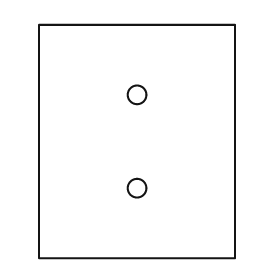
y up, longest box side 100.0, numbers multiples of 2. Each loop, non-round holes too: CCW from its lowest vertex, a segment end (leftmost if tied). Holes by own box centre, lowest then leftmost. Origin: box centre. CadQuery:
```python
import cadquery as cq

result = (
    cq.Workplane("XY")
    .moveTo(-42.0, -50.0)
    .lineTo(42.0, -50.0)
    .lineTo(42.0, 50.0)
    .lineTo(-42.0, 50.0)
    .close()
    .moveTo(0.0, -20.0)
    .circle(4.0)
    .moveTo(0.0, 20.0)
    .circle(4.0)
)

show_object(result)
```